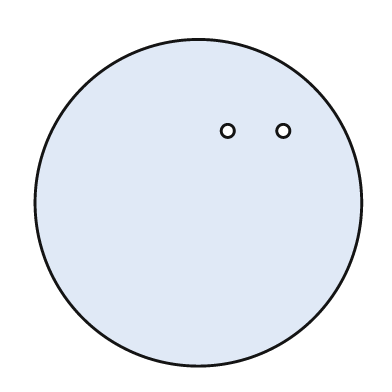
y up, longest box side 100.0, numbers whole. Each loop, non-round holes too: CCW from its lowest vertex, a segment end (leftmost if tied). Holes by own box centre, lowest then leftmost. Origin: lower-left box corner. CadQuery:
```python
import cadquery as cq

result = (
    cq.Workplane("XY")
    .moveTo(50.0, 50.0)
    .circle(50.0)
    .moveTo(59.0, 72.0)
    .circle(2.0)
    .moveTo(76.0, 72.0)
    .circle(2.0)
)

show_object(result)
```